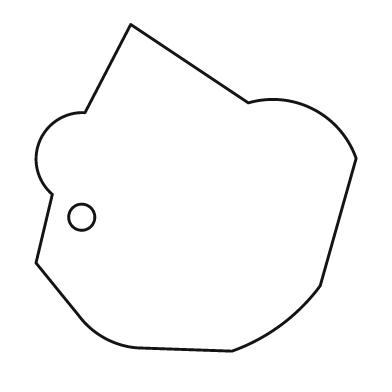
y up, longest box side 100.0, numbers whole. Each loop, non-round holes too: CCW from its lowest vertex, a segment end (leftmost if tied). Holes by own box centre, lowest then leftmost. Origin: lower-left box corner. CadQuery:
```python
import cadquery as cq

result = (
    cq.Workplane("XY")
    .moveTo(60.0, 0.0)
    .threePointArc((75.0, 8.0), (87.0, 20.0))
    .lineTo(98.0, 59.0)
    .threePointArc((85.0, 74.0), (65.0, 76.0))
    .lineTo(29.0, 100.0)
    .lineTo(15.0, 73.0)
    .threePointArc((1.0, 64.0), (5.0, 48.0))
    .lineTo(0.0, 27.0)
    .lineTo(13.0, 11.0)
    .threePointArc((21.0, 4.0), (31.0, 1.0))
    .close()
    .moveTo(14.0, 41.0)
    .circle(4.0)
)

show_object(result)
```